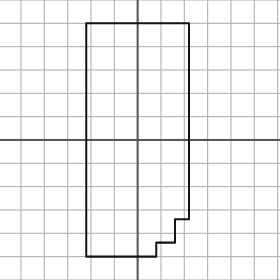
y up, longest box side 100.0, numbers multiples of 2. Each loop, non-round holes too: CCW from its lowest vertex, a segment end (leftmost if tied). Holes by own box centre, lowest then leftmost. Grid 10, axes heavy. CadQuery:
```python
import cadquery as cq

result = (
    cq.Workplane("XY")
    .moveTo(-22.0, -50.0)
    .lineTo(8.0, -50.0)
    .lineTo(8.0, -44.0)
    .lineTo(16.0, -44.0)
    .lineTo(16.0, -34.0)
    .lineTo(22.0, -34.0)
    .lineTo(22.0, 50.0)
    .lineTo(-22.0, 50.0)
    .close()
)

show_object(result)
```